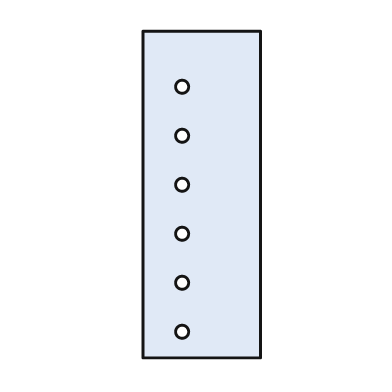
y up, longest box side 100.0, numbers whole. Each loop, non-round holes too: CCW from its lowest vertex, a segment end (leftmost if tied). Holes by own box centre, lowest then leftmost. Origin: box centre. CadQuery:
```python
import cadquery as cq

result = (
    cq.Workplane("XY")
    .moveTo(-18.0, -50.0)
    .lineTo(18.0, -50.0)
    .lineTo(18.0, 50.0)
    .lineTo(-18.0, 50.0)
    .close()
    .moveTo(-6.0, -42.0)
    .circle(2.0)
    .moveTo(-6.0, -27.0)
    .circle(2.0)
    .moveTo(-6.0, -12.0)
    .circle(2.0)
    .moveTo(-6.0, 3.0)
    .circle(2.0)
    .moveTo(-6.0, 18.0)
    .circle(2.0)
    .moveTo(-6.0, 33.0)
    .circle(2.0)
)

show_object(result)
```